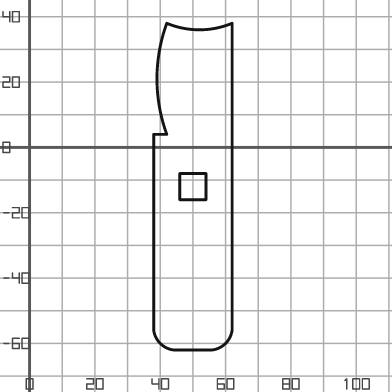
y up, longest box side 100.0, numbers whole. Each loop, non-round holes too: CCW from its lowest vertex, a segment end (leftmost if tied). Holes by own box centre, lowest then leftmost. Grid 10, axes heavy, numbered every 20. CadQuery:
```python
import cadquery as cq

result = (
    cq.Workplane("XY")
    .moveTo(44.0, -62.0)
    .lineTo(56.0, -62.0)
    .threePointArc((60.0, -60.0), (62.0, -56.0))
    .lineTo(62.0, 38.0)
    .threePointArc((52.0, 36.0), (42.0, 38.0))
    .threePointArc((39.0, 21.0), (42.0, 4.0))
    .lineTo(38.0, 4.0)
    .lineTo(38.0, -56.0)
    .threePointArc((40.0, -60.0), (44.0, -62.0))
    .close()
    .moveTo(46.0, -16.0)
    .lineTo(54.0, -16.0)
    .lineTo(54.0, -8.0)
    .lineTo(46.0, -8.0)
    .close()
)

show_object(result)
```